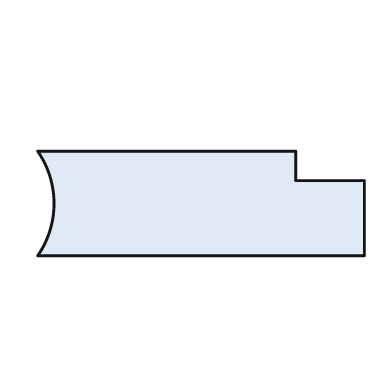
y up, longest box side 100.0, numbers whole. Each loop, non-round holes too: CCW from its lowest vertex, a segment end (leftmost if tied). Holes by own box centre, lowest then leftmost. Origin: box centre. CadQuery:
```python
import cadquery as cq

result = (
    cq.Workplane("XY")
    .moveTo(-50.0, -16.0)
    .lineTo(50.0, -16.0)
    .lineTo(50.0, 7.0)
    .lineTo(29.0, 7.0)
    .lineTo(29.0, 16.0)
    .lineTo(-50.0, 16.0)
    .threePointArc((-45.0, 0.0), (-50.0, -16.0))
    .close()
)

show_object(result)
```